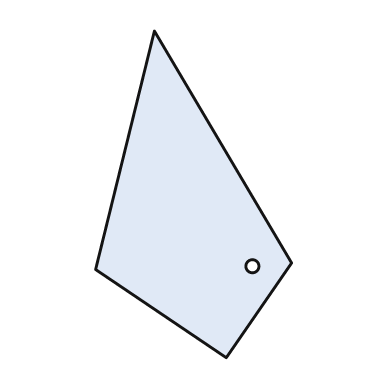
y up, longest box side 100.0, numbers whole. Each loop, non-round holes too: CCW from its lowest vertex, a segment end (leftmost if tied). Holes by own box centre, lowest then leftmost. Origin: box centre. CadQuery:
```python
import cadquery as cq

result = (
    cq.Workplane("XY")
    .moveTo(10.0, -50.0)
    .lineTo(30.0, -21.0)
    .lineTo(-12.0, 50.0)
    .lineTo(-30.0, -23.0)
    .close()
    .moveTo(18.0, -22.0)
    .circle(2.0)
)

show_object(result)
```